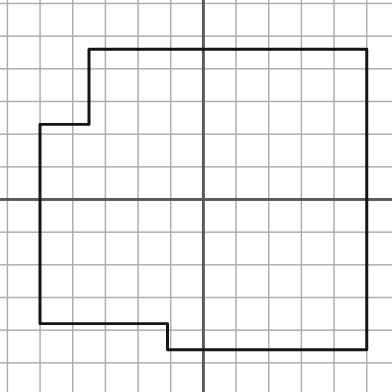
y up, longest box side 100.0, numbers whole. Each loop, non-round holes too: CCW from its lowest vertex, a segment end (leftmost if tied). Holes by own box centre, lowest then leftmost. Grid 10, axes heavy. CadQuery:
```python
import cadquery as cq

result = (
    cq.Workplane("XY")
    .moveTo(-11.0, -46.0)
    .lineTo(50.0, -46.0)
    .lineTo(50.0, 46.0)
    .lineTo(-35.0, 46.0)
    .lineTo(-35.0, 23.0)
    .lineTo(-50.0, 23.0)
    .lineTo(-50.0, -38.0)
    .lineTo(-11.0, -38.0)
    .close()
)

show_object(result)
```